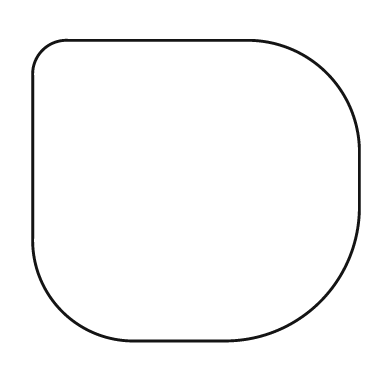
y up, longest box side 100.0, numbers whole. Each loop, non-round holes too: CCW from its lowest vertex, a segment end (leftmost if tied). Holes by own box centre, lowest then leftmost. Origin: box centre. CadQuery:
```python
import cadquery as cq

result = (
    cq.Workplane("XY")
    .moveTo(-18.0, -46.0)
    .lineTo(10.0, -46.0)
    .threePointArc((38.0, -34.0), (50.0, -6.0))
    .lineTo(50.0, 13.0)
    .threePointArc((40.0, 36.0), (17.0, 46.0))
    .lineTo(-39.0, 46.0)
    .threePointArc((-47.0, 43.0), (-50.0, 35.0))
    .lineTo(-50.0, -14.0)
    .threePointArc((-41.0, -37.0), (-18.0, -46.0))
    .close()
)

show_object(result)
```